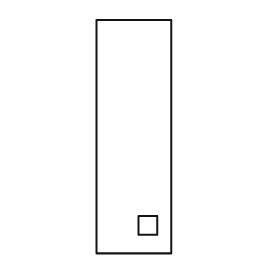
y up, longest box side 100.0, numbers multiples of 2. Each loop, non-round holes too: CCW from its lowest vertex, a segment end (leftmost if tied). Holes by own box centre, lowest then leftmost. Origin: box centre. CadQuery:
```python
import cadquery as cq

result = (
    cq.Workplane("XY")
    .moveTo(-16.0, -50.0)
    .lineTo(16.0, -50.0)
    .lineTo(16.0, 50.0)
    .lineTo(-16.0, 50.0)
    .close()
    .moveTo(2.0, -42.0)
    .lineTo(10.0, -42.0)
    .lineTo(10.0, -34.0)
    .lineTo(2.0, -34.0)
    .close()
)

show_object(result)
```